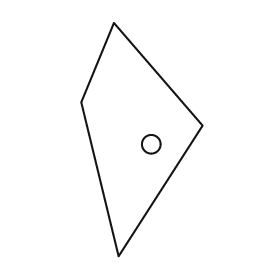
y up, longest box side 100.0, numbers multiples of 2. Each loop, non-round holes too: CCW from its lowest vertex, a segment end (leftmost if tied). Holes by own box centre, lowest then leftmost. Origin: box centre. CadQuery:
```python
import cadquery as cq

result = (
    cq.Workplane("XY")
    .moveTo(-10.0, -50.0)
    .lineTo(26.0, 6.0)
    .lineTo(-12.0, 50.0)
    .lineTo(-26.0, 16.0)
    .close()
    .moveTo(4.0, -2.0)
    .circle(4.0)
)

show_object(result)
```